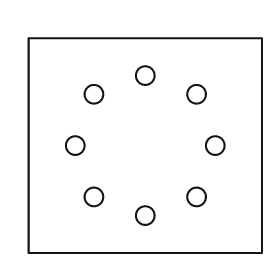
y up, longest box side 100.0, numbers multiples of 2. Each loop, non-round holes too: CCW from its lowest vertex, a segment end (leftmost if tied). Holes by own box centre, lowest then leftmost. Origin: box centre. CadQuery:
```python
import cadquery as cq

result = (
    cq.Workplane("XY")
    .moveTo(-50.0, -46.0)
    .lineTo(50.0, -46.0)
    .lineTo(50.0, 46.0)
    .lineTo(-50.0, 46.0)
    .close()
    .moveTo(0.0, -30.0)
    .circle(4.0)
    .moveTo(-22.0, -22.0)
    .circle(4.0)
    .moveTo(22.0, -22.0)
    .circle(4.0)
    .moveTo(-30.0, 0.0)
    .circle(4.0)
    .moveTo(30.0, 0.0)
    .circle(4.0)
    .moveTo(-22.0, 22.0)
    .circle(4.0)
    .moveTo(22.0, 22.0)
    .circle(4.0)
    .moveTo(0.0, 30.0)
    .circle(4.0)
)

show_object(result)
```